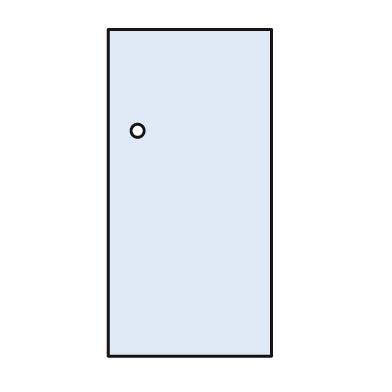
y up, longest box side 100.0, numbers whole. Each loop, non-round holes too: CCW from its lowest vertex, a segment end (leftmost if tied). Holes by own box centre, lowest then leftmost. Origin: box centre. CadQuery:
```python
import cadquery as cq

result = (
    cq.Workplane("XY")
    .moveTo(-25.0, -50.0)
    .lineTo(25.0, -50.0)
    .lineTo(25.0, 50.0)
    .lineTo(-25.0, 50.0)
    .close()
    .moveTo(-16.0, 19.0)
    .circle(2.0)
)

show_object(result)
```